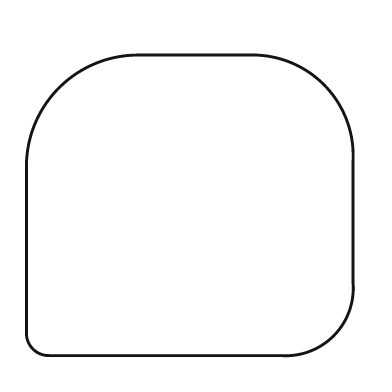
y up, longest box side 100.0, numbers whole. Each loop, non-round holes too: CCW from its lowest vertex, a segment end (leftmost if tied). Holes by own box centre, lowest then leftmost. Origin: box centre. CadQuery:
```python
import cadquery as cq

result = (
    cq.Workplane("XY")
    .moveTo(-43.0, -46.0)
    .lineTo(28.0, -46.0)
    .threePointArc((44.0, -40.0), (50.0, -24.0))
    .lineTo(50.0, 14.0)
    .threePointArc((41.0, 37.0), (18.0, 46.0))
    .lineTo(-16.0, 46.0)
    .threePointArc((-40.0, 36.0), (-50.0, 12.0))
    .lineTo(-50.0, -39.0)
    .threePointArc((-48.0, -44.0), (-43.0, -46.0))
    .close()
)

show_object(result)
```